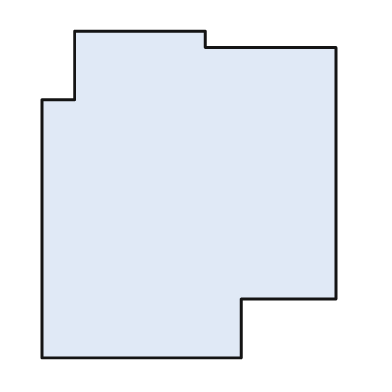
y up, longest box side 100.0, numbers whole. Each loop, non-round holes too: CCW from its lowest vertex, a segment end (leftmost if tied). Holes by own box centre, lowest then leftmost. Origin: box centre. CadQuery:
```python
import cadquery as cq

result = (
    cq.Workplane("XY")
    .moveTo(-45.0, -50.0)
    .lineTo(16.0, -50.0)
    .lineTo(16.0, -32.0)
    .lineTo(45.0, -32.0)
    .lineTo(45.0, 45.0)
    .lineTo(5.0, 45.0)
    .lineTo(5.0, 50.0)
    .lineTo(-35.0, 50.0)
    .lineTo(-35.0, 29.0)
    .lineTo(-45.0, 29.0)
    .close()
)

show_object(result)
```